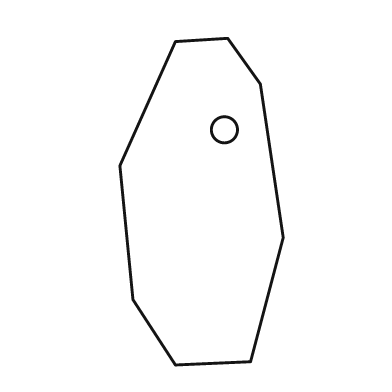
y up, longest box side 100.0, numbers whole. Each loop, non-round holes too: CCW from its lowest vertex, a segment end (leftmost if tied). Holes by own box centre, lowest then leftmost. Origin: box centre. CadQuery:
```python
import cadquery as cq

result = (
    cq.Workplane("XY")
    .moveTo(-8.0, -50.0)
    .lineTo(15.0, -49.0)
    .lineTo(25.0, -11.0)
    .lineTo(18.0, 36.0)
    .lineTo(8.0, 50.0)
    .lineTo(-8.0, 49.0)
    .lineTo(-25.0, 11.0)
    .lineTo(-21.0, -30.0)
    .close()
    .moveTo(7.0, 22.0)
    .circle(4.0)
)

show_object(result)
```